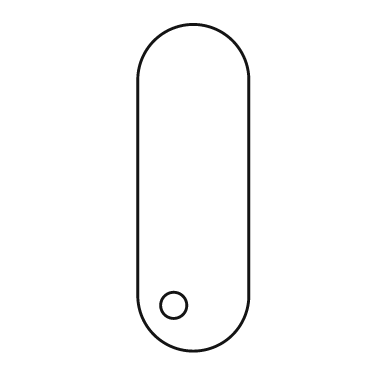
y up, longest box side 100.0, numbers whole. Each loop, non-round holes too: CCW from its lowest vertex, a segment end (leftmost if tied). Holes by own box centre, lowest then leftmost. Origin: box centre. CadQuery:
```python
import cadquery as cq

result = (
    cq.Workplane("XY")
    .moveTo(-17.0, -33.0)
    .threePointArc((0.0, -50.0), (17.0, -33.0))
    .lineTo(17.0, 33.0)
    .threePointArc((0.0, 50.0), (-17.0, 33.0))
    .close()
    .moveTo(-6.0, -36.0)
    .circle(4.0)
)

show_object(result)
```